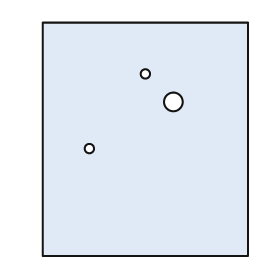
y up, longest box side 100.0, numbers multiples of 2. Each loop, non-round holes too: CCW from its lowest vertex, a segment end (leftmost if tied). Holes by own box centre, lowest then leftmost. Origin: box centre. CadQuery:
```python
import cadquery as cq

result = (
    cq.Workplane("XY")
    .moveTo(-44.0, -50.0)
    .lineTo(44.0, -50.0)
    .lineTo(44.0, 50.0)
    .lineTo(-44.0, 50.0)
    .close()
    .moveTo(-24.0, -4.0)
    .circle(2.0)
    .moveTo(12.0, 16.0)
    .circle(4.0)
    .moveTo(0.0, 28.0)
    .circle(2.0)
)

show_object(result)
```